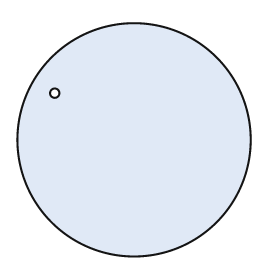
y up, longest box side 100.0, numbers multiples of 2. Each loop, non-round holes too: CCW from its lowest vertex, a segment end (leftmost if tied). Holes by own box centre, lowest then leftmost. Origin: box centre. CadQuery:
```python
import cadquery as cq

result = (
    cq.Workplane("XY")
    .moveTo(0.0, 0.0)
    .circle(50.0)
    .moveTo(-34.0, 20.0)
    .circle(2.0)
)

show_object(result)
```